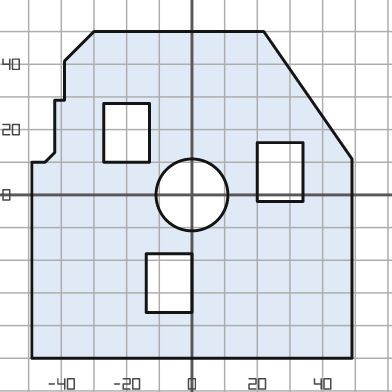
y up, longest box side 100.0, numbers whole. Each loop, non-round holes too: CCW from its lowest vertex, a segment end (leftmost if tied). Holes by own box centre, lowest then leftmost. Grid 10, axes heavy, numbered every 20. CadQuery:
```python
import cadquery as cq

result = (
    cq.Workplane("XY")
    .moveTo(-49.0, -50.0)
    .lineTo(49.0, -50.0)
    .lineTo(49.0, 11.0)
    .lineTo(22.0, 50.0)
    .lineTo(-30.0, 50.0)
    .lineTo(-39.0, 41.0)
    .lineTo(-39.0, 29.0)
    .lineTo(-42.0, 29.0)
    .lineTo(-42.0, 13.0)
    .lineTo(-45.0, 10.0)
    .lineTo(-49.0, 10.0)
    .close()
    .moveTo(-14.0, -36.0)
    .lineTo(0.0, -36.0)
    .lineTo(0.0, -18.0)
    .lineTo(-14.0, -18.0)
    .close()
    .moveTo(0.0, 0.0)
    .circle(11.0)
    .moveTo(20.0, -2.0)
    .lineTo(34.0, -2.0)
    .lineTo(34.0, 16.0)
    .lineTo(20.0, 16.0)
    .close()
    .moveTo(-27.0, 10.0)
    .lineTo(-13.0, 10.0)
    .lineTo(-13.0, 28.0)
    .lineTo(-27.0, 28.0)
    .close()
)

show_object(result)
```